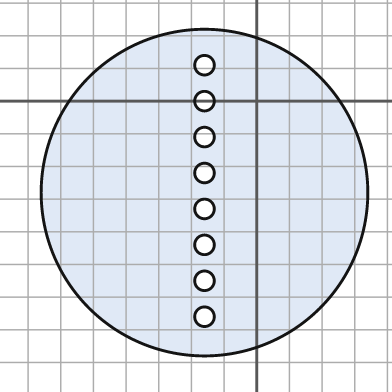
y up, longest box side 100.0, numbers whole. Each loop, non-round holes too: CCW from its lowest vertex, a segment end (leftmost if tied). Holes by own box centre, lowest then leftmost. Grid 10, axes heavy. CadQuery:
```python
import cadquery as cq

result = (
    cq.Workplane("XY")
    .moveTo(-16.0, -28.0)
    .circle(50.0)
    .moveTo(-16.0, -66.0)
    .circle(3.0)
    .moveTo(-16.0, -55.0)
    .circle(3.0)
    .moveTo(-16.0, -44.0)
    .circle(3.0)
    .moveTo(-16.0, -33.0)
    .circle(3.0)
    .moveTo(-16.0, -22.0)
    .circle(3.0)
    .moveTo(-16.0, -11.0)
    .circle(3.0)
    .moveTo(-16.0, 0.0)
    .circle(3.0)
    .moveTo(-16.0, 11.0)
    .circle(3.0)
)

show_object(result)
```